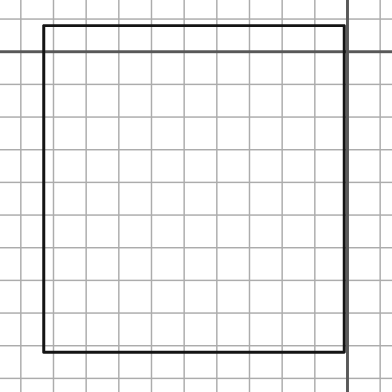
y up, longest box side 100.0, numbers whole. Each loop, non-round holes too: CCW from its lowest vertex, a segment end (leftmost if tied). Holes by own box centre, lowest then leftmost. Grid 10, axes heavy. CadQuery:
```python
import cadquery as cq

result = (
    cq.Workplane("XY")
    .moveTo(-93.0, -92.0)
    .lineTo(-1.0, -92.0)
    .lineTo(-1.0, 8.0)
    .lineTo(-93.0, 8.0)
    .close()
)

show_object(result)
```